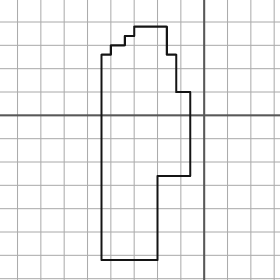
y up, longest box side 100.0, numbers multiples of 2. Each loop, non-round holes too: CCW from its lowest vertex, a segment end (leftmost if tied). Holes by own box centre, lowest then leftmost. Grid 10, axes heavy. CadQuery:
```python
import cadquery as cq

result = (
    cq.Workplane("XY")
    .moveTo(-44.0, -62.0)
    .lineTo(-20.0, -62.0)
    .lineTo(-20.0, -26.0)
    .lineTo(-6.0, -26.0)
    .lineTo(-6.0, 10.0)
    .lineTo(-12.0, 10.0)
    .lineTo(-12.0, 26.0)
    .lineTo(-16.0, 26.0)
    .lineTo(-16.0, 38.0)
    .lineTo(-30.0, 38.0)
    .lineTo(-30.0, 34.0)
    .lineTo(-34.0, 34.0)
    .lineTo(-34.0, 30.0)
    .lineTo(-40.0, 30.0)
    .lineTo(-40.0, 26.0)
    .lineTo(-44.0, 26.0)
    .close()
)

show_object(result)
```